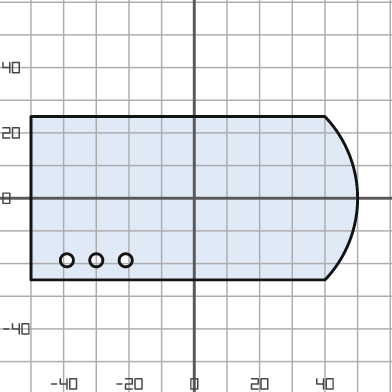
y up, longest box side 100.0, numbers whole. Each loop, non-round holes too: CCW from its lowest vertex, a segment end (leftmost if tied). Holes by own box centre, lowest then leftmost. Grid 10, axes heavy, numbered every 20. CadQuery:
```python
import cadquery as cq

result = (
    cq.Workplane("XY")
    .moveTo(-50.0, -25.0)
    .lineTo(40.0, -25.0)
    .threePointArc((50.0, 0.0), (40.0, 25.0))
    .lineTo(-50.0, 25.0)
    .close()
    .moveTo(-39.0, -19.0)
    .circle(2.0)
    .moveTo(-30.0, -19.0)
    .circle(2.0)
    .moveTo(-21.0, -19.0)
    .circle(2.0)
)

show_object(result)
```